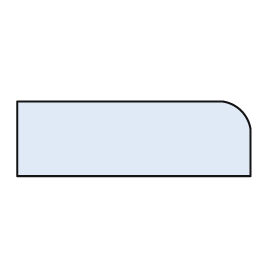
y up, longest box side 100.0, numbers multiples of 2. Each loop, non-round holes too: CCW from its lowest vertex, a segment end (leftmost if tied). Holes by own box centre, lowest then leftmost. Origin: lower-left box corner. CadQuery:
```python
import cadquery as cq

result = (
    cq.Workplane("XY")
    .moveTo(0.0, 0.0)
    .lineTo(100.0, 0.0)
    .lineTo(100.0, 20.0)
    .threePointArc((96.0, 28.0), (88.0, 32.0))
    .lineTo(0.0, 32.0)
    .close()
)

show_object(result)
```